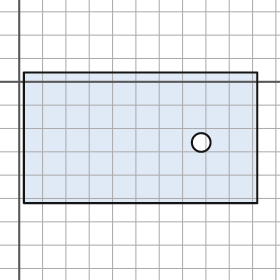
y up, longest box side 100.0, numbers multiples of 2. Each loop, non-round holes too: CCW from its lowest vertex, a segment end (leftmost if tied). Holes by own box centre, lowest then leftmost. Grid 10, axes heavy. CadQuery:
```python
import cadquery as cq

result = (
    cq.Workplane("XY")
    .moveTo(2.0, -52.0)
    .lineTo(102.0, -52.0)
    .lineTo(102.0, 4.0)
    .lineTo(2.0, 4.0)
    .close()
    .moveTo(78.0, -26.0)
    .circle(4.0)
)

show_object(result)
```